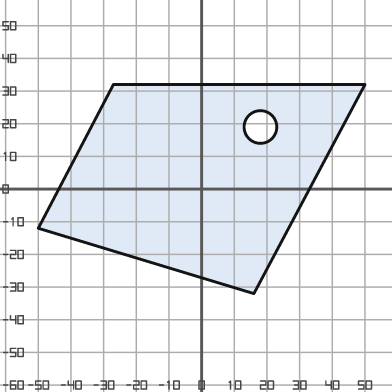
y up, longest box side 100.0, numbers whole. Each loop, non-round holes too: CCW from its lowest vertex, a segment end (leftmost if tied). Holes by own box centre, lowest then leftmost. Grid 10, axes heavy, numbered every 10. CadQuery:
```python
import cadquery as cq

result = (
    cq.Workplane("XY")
    .moveTo(16.0, -32.0)
    .lineTo(50.0, 32.0)
    .lineTo(-27.0, 32.0)
    .lineTo(-50.0, -12.0)
    .close()
    .moveTo(18.0, 19.0)
    .circle(5.0)
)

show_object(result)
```